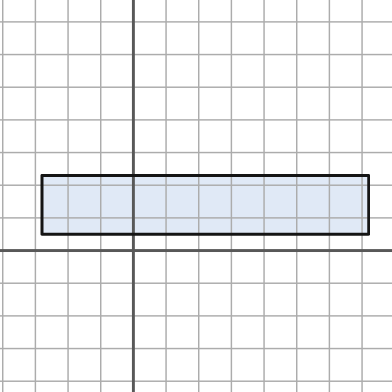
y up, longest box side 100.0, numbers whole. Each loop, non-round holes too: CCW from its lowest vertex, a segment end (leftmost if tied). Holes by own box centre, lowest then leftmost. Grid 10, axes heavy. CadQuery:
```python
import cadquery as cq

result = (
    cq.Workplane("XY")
    .moveTo(-28.0, 5.0)
    .lineTo(72.0, 5.0)
    .lineTo(72.0, 23.0)
    .lineTo(-28.0, 23.0)
    .close()
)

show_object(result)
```